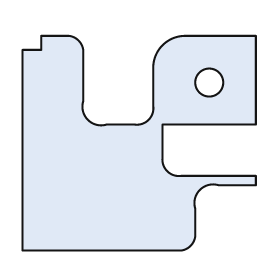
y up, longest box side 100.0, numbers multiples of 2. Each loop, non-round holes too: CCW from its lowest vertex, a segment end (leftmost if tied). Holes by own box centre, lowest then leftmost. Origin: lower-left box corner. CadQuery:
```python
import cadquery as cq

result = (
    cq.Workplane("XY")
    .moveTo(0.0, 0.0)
    .lineTo(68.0, 0.0)
    .threePointArc((72.0, 2.0), (74.0, 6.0))
    .lineTo(74.0, 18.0)
    .threePointArc((76.0, 26.0), (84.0, 28.0))
    .lineTo(100.0, 28.0)
    .lineTo(100.0, 32.0)
    .lineTo(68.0, 32.0)
    .threePointArc((62.0, 34.0), (60.0, 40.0))
    .lineTo(60.0, 54.0)
    .lineTo(100.0, 54.0)
    .lineTo(100.0, 92.0)
    .lineTo(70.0, 92.0)
    .threePointArc((60.0, 88.0), (56.0, 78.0))
    .lineTo(56.0, 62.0)
    .threePointArc((54.0, 56.0), (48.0, 54.0))
    .lineTo(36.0, 54.0)
    .threePointArc((28.0, 56.0), (26.0, 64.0))
    .lineTo(26.0, 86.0)
    .threePointArc((24.0, 90.0), (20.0, 92.0))
    .lineTo(8.0, 92.0)
    .lineTo(8.0, 86.0)
    .lineTo(0.0, 86.0)
    .close()
    .moveTo(80.0, 72.0)
    .circle(6.0)
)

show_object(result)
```